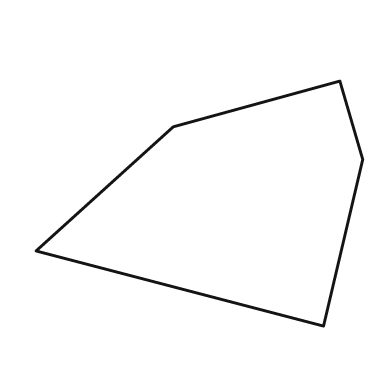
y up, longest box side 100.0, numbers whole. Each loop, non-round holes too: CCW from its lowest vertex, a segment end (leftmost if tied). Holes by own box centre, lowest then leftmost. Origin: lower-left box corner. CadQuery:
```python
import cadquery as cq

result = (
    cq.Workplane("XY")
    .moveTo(88.0, 0.0)
    .lineTo(100.0, 51.0)
    .lineTo(93.0, 75.0)
    .lineTo(42.0, 61.0)
    .lineTo(0.0, 23.0)
    .close()
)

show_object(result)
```